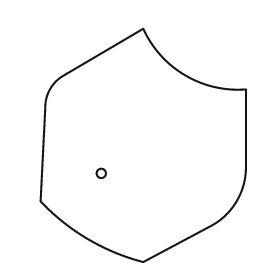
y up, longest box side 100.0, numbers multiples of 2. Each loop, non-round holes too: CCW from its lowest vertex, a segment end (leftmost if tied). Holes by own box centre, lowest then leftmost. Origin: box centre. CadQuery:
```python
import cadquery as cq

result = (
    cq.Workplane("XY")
    .moveTo(0.0, -50.0)
    .lineTo(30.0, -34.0)
    .threePointArc((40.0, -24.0), (44.0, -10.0))
    .lineTo(44.0, 24.0)
    .threePointArc((18.0, 30.0), (0.0, 50.0))
    .lineTo(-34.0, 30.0)
    .threePointArc((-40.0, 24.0), (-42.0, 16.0))
    .lineTo(-44.0, -24.0)
    .threePointArc((-24.0, -40.0), (0.0, -50.0))
    .close()
    .moveTo(-18.0, -12.0)
    .circle(2.0)
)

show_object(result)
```